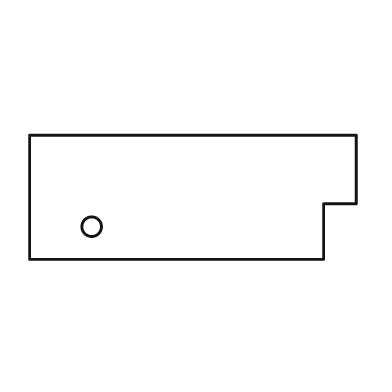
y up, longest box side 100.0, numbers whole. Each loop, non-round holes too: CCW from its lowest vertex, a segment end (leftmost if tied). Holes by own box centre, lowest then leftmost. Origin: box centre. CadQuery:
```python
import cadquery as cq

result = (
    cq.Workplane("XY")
    .moveTo(-50.0, -19.0)
    .lineTo(40.0, -19.0)
    .lineTo(40.0, -2.0)
    .lineTo(50.0, -2.0)
    .lineTo(50.0, 19.0)
    .lineTo(-50.0, 19.0)
    .close()
    .moveTo(-31.0, -9.0)
    .circle(3.0)
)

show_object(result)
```